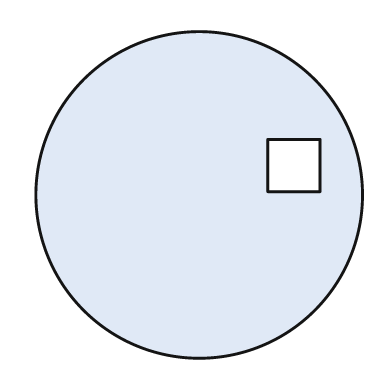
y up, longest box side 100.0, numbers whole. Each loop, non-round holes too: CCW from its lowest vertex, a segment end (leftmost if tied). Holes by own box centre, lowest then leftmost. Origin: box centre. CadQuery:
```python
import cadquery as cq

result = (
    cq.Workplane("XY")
    .moveTo(0.0, 0.0)
    .circle(50.0)
    .moveTo(21.0, 1.0)
    .lineTo(37.0, 1.0)
    .lineTo(37.0, 17.0)
    .lineTo(21.0, 17.0)
    .close()
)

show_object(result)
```